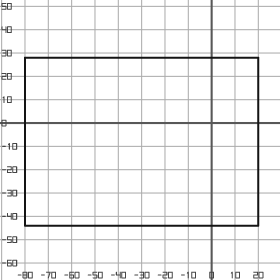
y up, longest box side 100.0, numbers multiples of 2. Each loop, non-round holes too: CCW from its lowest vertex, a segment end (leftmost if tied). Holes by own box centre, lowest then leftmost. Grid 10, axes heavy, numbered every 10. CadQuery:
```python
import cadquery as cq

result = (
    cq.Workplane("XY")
    .moveTo(-80.0, -44.0)
    .lineTo(20.0, -44.0)
    .lineTo(20.0, 28.0)
    .lineTo(-80.0, 28.0)
    .close()
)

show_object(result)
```